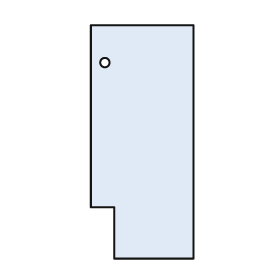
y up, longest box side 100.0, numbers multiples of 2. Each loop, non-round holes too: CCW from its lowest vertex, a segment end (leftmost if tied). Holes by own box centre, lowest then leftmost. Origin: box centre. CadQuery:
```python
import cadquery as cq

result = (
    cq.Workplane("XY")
    .moveTo(-12.0, -50.0)
    .lineTo(22.0, -50.0)
    .lineTo(22.0, 50.0)
    .lineTo(-22.0, 50.0)
    .lineTo(-22.0, -28.0)
    .lineTo(-12.0, -28.0)
    .close()
    .moveTo(-16.0, 34.0)
    .circle(2.0)
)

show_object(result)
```